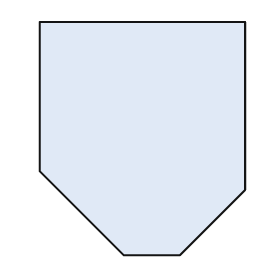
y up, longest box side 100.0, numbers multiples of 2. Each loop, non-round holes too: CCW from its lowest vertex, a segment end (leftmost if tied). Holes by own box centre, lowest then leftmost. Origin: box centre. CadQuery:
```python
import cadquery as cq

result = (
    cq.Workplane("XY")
    .moveTo(-8.0, -50.0)
    .lineTo(16.0, -50.0)
    .lineTo(44.0, -22.0)
    .lineTo(44.0, 50.0)
    .lineTo(-44.0, 50.0)
    .lineTo(-44.0, -14.0)
    .close()
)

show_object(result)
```